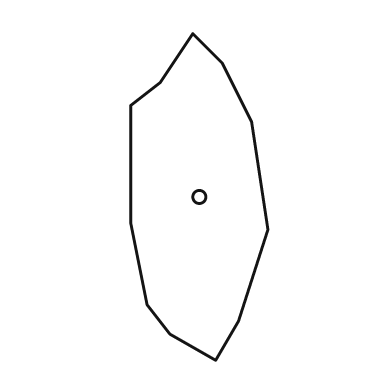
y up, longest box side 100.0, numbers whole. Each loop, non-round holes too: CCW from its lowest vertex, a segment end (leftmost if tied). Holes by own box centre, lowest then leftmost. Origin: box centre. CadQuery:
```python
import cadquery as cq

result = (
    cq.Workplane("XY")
    .moveTo(5.0, -50.0)
    .lineTo(12.0, -38.0)
    .lineTo(21.0, -10.0)
    .lineTo(16.0, 23.0)
    .lineTo(7.0, 41.0)
    .lineTo(-2.0, 50.0)
    .lineTo(-12.0, 35.0)
    .lineTo(-21.0, 28.0)
    .lineTo(-21.0, -8.0)
    .lineTo(-16.0, -33.0)
    .lineTo(-9.0, -42.0)
    .close()
    .moveTo(0.0, 0.0)
    .circle(2.0)
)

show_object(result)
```